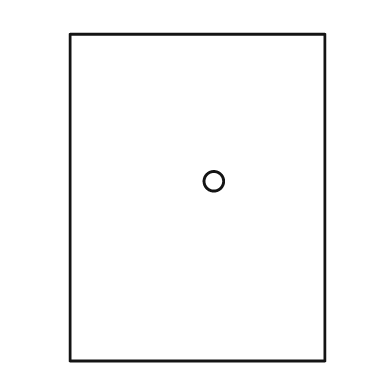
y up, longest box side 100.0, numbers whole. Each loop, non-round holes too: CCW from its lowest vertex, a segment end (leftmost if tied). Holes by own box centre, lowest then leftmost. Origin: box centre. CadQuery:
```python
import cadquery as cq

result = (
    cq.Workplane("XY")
    .moveTo(-39.0, -50.0)
    .lineTo(39.0, -50.0)
    .lineTo(39.0, 50.0)
    .lineTo(-39.0, 50.0)
    .close()
    .moveTo(5.0, 5.0)
    .circle(3.0)
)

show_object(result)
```